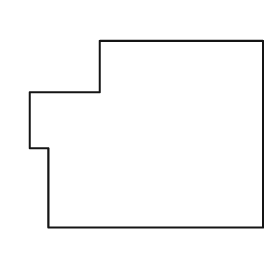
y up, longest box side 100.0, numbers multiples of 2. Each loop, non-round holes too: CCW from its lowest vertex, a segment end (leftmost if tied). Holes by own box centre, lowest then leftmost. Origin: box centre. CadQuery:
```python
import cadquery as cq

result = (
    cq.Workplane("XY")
    .moveTo(-42.0, -40.0)
    .lineTo(50.0, -40.0)
    .lineTo(50.0, 40.0)
    .lineTo(-20.0, 40.0)
    .lineTo(-20.0, 18.0)
    .lineTo(-50.0, 18.0)
    .lineTo(-50.0, -6.0)
    .lineTo(-42.0, -6.0)
    .close()
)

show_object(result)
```